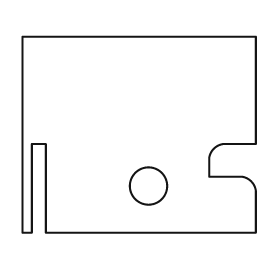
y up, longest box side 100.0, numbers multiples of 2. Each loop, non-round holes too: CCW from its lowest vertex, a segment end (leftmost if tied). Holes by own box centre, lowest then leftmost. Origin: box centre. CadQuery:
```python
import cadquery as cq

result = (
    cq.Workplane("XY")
    .moveTo(-50.0, -42.0)
    .lineTo(-46.0, -42.0)
    .lineTo(-46.0, -4.0)
    .lineTo(-40.0, -4.0)
    .lineTo(-40.0, -42.0)
    .lineTo(50.0, -42.0)
    .lineTo(50.0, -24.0)
    .threePointArc((48.0, -20.0), (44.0, -18.0))
    .lineTo(30.0, -18.0)
    .lineTo(30.0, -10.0)
    .threePointArc((32.0, -6.0), (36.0, -4.0))
    .lineTo(50.0, -4.0)
    .lineTo(50.0, 42.0)
    .lineTo(-50.0, 42.0)
    .close()
    .moveTo(4.0, -22.0)
    .circle(8.0)
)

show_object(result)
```